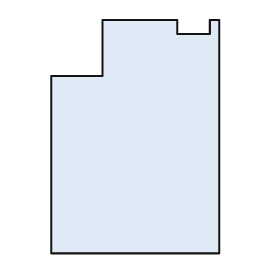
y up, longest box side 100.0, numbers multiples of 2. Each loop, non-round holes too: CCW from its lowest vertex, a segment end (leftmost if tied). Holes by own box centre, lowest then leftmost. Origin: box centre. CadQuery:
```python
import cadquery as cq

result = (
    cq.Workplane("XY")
    .moveTo(-36.0, -50.0)
    .lineTo(36.0, -50.0)
    .lineTo(36.0, 50.0)
    .lineTo(32.0, 50.0)
    .lineTo(32.0, 44.0)
    .lineTo(18.0, 44.0)
    .lineTo(18.0, 50.0)
    .lineTo(-14.0, 50.0)
    .lineTo(-14.0, 26.0)
    .lineTo(-36.0, 26.0)
    .close()
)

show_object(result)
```